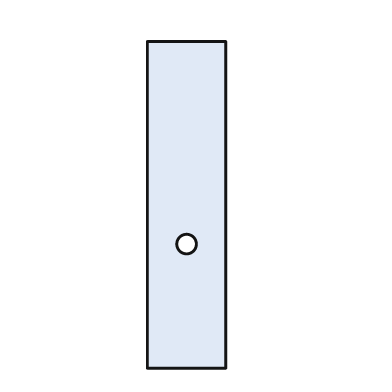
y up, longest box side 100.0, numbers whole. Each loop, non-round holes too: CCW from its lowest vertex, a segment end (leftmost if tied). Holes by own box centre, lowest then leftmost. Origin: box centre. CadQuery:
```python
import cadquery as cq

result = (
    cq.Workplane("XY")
    .moveTo(-12.0, -50.0)
    .lineTo(12.0, -50.0)
    .lineTo(12.0, 50.0)
    .lineTo(-12.0, 50.0)
    .close()
    .moveTo(0.0, -12.0)
    .circle(3.0)
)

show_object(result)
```